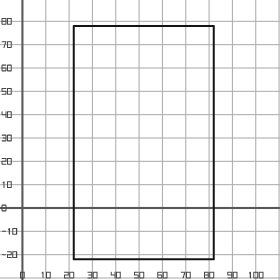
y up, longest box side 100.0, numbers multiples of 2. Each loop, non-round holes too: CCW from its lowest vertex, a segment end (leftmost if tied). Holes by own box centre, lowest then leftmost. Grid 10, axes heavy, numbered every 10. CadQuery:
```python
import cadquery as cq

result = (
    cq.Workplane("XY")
    .moveTo(22.0, -22.0)
    .lineTo(82.0, -22.0)
    .lineTo(82.0, 78.0)
    .lineTo(22.0, 78.0)
    .close()
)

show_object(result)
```